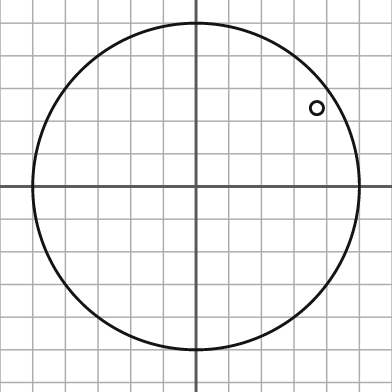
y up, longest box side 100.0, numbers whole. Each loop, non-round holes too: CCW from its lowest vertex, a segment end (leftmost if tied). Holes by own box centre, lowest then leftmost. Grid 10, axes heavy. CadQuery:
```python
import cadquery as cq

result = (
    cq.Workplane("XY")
    .moveTo(0.0, 0.0)
    .circle(50.0)
    .moveTo(37.0, 24.0)
    .circle(2.0)
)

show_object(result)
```